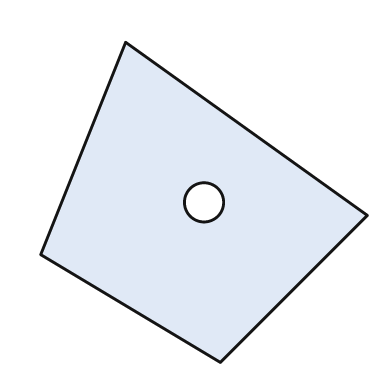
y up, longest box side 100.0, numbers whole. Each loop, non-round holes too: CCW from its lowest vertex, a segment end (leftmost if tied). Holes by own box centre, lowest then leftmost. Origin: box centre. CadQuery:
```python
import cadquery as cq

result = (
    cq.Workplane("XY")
    .moveTo(5.0, -49.0)
    .lineTo(50.0, -4.0)
    .lineTo(-24.0, 49.0)
    .lineTo(-50.0, -16.0)
    .close()
    .moveTo(0.0, 0.0)
    .circle(6.0)
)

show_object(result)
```